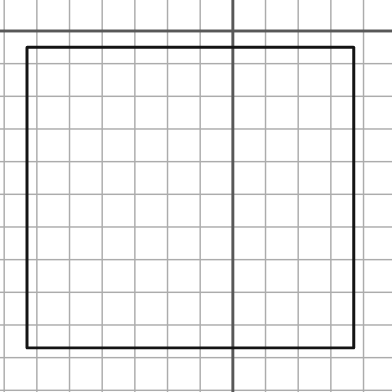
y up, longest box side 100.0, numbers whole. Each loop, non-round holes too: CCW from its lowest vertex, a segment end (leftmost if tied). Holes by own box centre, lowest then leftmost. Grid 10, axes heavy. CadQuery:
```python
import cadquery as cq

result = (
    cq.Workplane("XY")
    .moveTo(-63.0, -97.0)
    .lineTo(37.0, -97.0)
    .lineTo(37.0, -5.0)
    .lineTo(-63.0, -5.0)
    .close()
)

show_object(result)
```